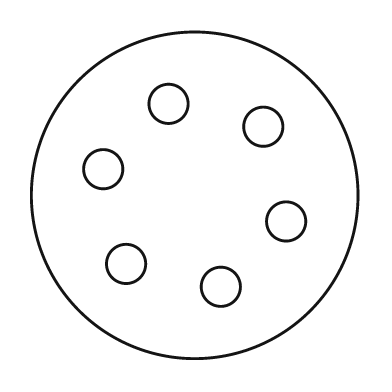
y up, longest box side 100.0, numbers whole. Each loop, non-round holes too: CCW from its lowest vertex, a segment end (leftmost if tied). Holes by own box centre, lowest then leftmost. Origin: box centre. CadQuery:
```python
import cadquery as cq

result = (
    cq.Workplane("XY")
    .moveTo(0.0, 0.0)
    .circle(50.0)
    .moveTo(8.0, -28.0)
    .circle(6.0)
    .moveTo(-21.0, -21.0)
    .circle(6.0)
    .moveTo(28.0, -8.0)
    .circle(6.0)
    .moveTo(-28.0, 8.0)
    .circle(6.0)
    .moveTo(21.0, 21.0)
    .circle(6.0)
    .moveTo(-8.0, 28.0)
    .circle(6.0)
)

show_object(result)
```